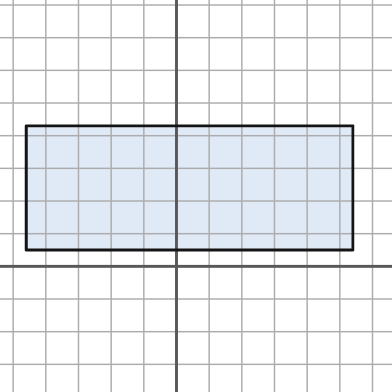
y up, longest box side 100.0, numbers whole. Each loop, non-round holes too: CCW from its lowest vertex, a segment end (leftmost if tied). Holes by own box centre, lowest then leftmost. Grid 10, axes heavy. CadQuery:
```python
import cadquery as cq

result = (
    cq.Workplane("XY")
    .moveTo(-46.0, 5.0)
    .lineTo(54.0, 5.0)
    .lineTo(54.0, 43.0)
    .lineTo(-46.0, 43.0)
    .close()
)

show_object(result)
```